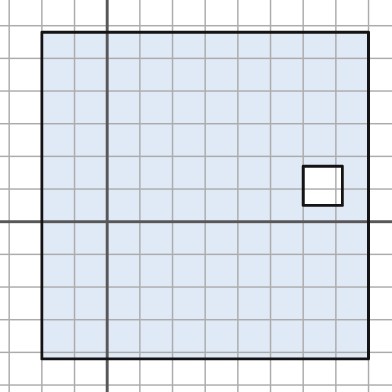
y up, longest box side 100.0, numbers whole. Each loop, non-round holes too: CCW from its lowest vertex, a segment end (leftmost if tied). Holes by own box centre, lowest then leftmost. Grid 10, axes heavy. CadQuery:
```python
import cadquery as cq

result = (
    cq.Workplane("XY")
    .moveTo(-20.0, -42.0)
    .lineTo(80.0, -42.0)
    .lineTo(80.0, 58.0)
    .lineTo(-20.0, 58.0)
    .close()
    .moveTo(60.0, 5.0)
    .lineTo(72.0, 5.0)
    .lineTo(72.0, 17.0)
    .lineTo(60.0, 17.0)
    .close()
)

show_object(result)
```